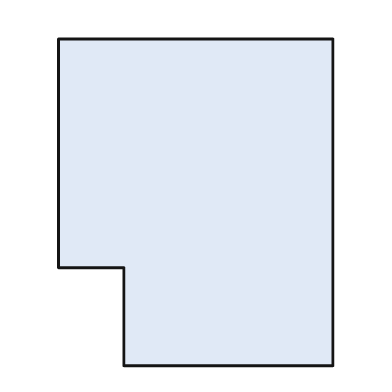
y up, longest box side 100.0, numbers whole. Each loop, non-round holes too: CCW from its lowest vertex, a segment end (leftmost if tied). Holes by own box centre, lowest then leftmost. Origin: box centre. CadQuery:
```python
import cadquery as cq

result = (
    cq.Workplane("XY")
    .moveTo(-22.0, -50.0)
    .lineTo(42.0, -50.0)
    .lineTo(42.0, 50.0)
    .lineTo(-42.0, 50.0)
    .lineTo(-42.0, -20.0)
    .lineTo(-22.0, -20.0)
    .close()
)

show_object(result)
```